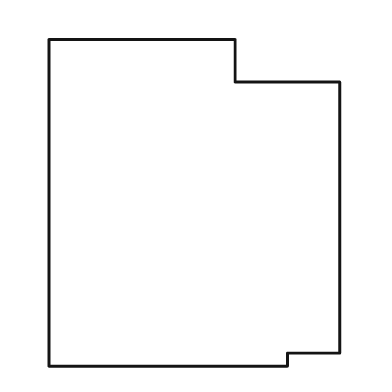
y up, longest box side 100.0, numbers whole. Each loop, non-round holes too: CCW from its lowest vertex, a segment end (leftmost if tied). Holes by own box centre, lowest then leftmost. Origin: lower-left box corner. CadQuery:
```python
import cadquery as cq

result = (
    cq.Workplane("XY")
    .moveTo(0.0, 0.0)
    .lineTo(73.0, 0.0)
    .lineTo(73.0, 4.0)
    .lineTo(89.0, 4.0)
    .lineTo(89.0, 87.0)
    .lineTo(57.0, 87.0)
    .lineTo(57.0, 100.0)
    .lineTo(0.0, 100.0)
    .close()
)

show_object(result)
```